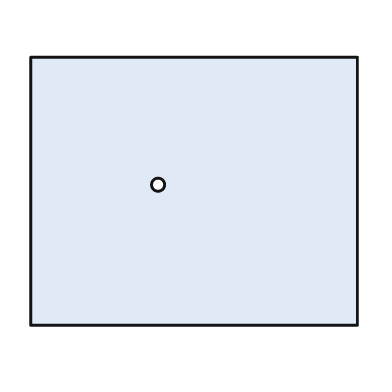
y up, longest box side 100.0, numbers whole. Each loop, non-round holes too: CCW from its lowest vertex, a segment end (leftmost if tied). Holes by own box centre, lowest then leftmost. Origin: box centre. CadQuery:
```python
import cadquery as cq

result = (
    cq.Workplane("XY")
    .moveTo(-50.0, -41.0)
    .lineTo(50.0, -41.0)
    .lineTo(50.0, 41.0)
    .lineTo(-50.0, 41.0)
    .close()
    .moveTo(-11.0, 2.0)
    .circle(2.0)
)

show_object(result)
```